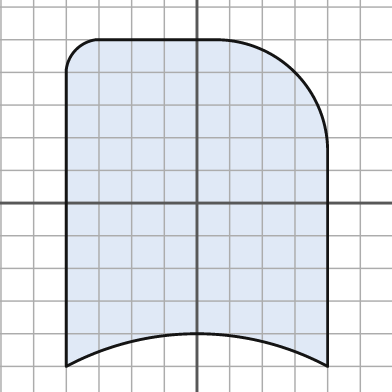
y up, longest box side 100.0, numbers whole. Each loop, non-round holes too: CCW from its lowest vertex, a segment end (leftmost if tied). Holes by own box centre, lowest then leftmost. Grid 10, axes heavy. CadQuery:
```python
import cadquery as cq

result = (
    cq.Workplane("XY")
    .moveTo(-40.0, -50.0)
    .threePointArc((0.0, -40.0), (40.0, -50.0))
    .lineTo(40.0, 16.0)
    .threePointArc((30.0, 40.0), (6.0, 50.0))
    .lineTo(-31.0, 50.0)
    .threePointArc((-37.0, 47.0), (-40.0, 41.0))
    .close()
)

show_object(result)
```